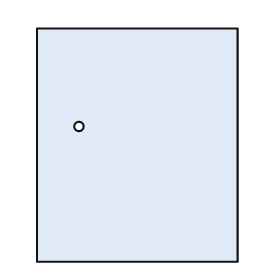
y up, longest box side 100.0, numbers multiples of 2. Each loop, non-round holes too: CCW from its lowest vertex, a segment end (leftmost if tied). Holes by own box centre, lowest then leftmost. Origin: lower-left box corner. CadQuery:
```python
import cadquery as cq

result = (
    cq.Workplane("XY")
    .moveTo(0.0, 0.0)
    .lineTo(86.0, 0.0)
    .lineTo(86.0, 100.0)
    .lineTo(0.0, 100.0)
    .close()
    .moveTo(18.0, 58.0)
    .circle(2.0)
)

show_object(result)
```